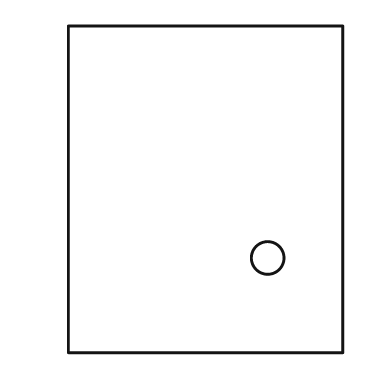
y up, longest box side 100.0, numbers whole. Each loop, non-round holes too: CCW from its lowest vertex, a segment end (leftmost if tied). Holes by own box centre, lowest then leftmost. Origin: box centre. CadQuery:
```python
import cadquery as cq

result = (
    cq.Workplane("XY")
    .moveTo(-42.0, -50.0)
    .lineTo(42.0, -50.0)
    .lineTo(42.0, 50.0)
    .lineTo(-42.0, 50.0)
    .close()
    .moveTo(19.0, -21.0)
    .circle(5.0)
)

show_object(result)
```